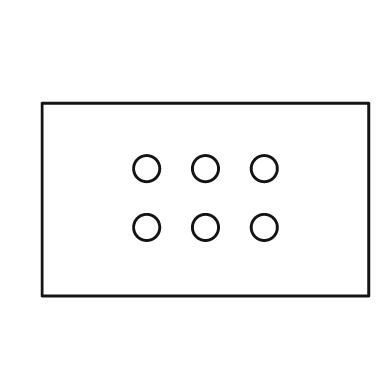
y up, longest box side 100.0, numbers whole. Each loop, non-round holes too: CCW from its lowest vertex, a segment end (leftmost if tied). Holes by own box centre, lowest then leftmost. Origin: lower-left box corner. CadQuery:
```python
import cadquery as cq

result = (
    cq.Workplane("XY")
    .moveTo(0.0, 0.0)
    .lineTo(100.0, 0.0)
    .lineTo(100.0, 59.0)
    .lineTo(0.0, 59.0)
    .close()
    .moveTo(32.0, 21.0)
    .circle(4.0)
    .moveTo(50.0, 21.0)
    .circle(4.0)
    .moveTo(68.0, 21.0)
    .circle(4.0)
    .moveTo(32.0, 39.0)
    .circle(4.0)
    .moveTo(50.0, 39.0)
    .circle(4.0)
    .moveTo(68.0, 39.0)
    .circle(4.0)
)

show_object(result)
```